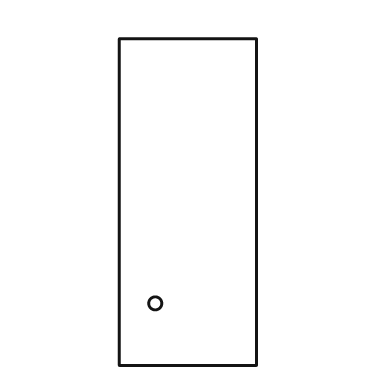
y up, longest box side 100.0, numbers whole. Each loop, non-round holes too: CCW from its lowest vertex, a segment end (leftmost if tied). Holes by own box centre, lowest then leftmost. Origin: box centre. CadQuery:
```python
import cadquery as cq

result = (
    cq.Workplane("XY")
    .moveTo(-21.0, -50.0)
    .lineTo(21.0, -50.0)
    .lineTo(21.0, 50.0)
    .lineTo(-21.0, 50.0)
    .close()
    .moveTo(-10.0, -31.0)
    .circle(2.0)
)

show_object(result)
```